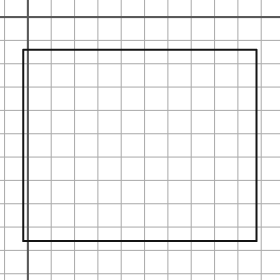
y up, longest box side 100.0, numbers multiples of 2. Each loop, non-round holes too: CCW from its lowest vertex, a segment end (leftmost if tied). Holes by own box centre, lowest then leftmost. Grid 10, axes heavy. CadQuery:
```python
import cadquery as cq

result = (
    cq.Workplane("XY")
    .moveTo(-2.0, -96.0)
    .lineTo(98.0, -96.0)
    .lineTo(98.0, -14.0)
    .lineTo(-2.0, -14.0)
    .close()
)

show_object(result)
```